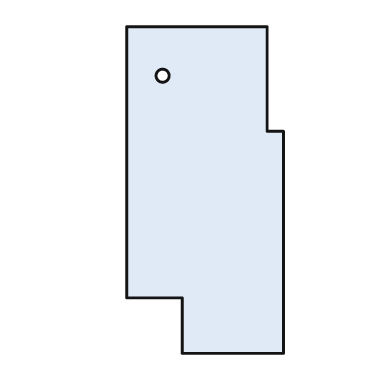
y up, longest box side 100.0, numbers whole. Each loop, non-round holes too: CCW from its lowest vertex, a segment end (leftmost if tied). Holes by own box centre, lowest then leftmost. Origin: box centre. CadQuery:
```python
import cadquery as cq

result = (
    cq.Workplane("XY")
    .moveTo(-7.0, -50.0)
    .lineTo(24.0, -50.0)
    .lineTo(24.0, 18.0)
    .lineTo(19.0, 18.0)
    .lineTo(19.0, 50.0)
    .lineTo(-24.0, 50.0)
    .lineTo(-24.0, -33.0)
    .lineTo(-7.0, -33.0)
    .close()
    .moveTo(-13.0, 35.0)
    .circle(2.0)
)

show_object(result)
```